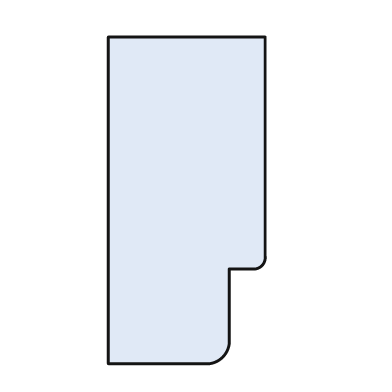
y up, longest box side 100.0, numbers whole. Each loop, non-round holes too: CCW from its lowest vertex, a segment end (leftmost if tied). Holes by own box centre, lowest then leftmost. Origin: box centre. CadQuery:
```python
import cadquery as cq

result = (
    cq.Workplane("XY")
    .moveTo(-24.0, -50.0)
    .lineTo(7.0, -50.0)
    .threePointArc((11.0, -48.0), (13.0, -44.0))
    .lineTo(13.0, -21.0)
    .lineTo(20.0, -21.0)
    .threePointArc((23.0, -20.0), (24.0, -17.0))
    .lineTo(24.0, 50.0)
    .lineTo(-24.0, 50.0)
    .close()
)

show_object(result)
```